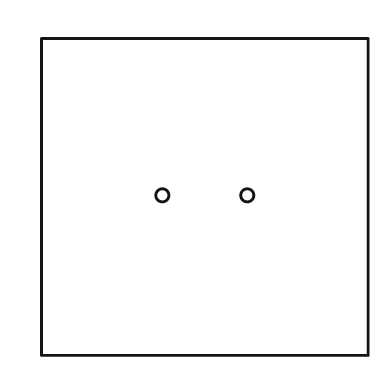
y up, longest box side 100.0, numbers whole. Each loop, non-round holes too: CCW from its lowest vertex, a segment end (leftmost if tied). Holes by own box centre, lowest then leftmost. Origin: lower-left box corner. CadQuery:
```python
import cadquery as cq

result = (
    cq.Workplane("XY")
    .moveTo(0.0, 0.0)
    .lineTo(100.0, 0.0)
    .lineTo(100.0, 97.0)
    .lineTo(0.0, 97.0)
    .close()
    .moveTo(37.0, 49.0)
    .circle(2.0)
    .moveTo(63.0, 49.0)
    .circle(2.0)
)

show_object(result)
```